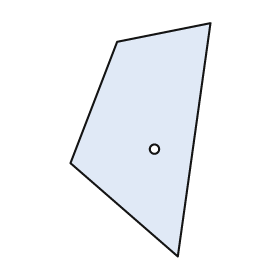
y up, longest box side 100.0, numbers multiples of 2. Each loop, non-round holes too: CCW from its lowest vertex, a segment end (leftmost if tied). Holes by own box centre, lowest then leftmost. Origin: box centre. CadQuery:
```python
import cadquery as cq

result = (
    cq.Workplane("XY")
    .moveTo(16.0, -50.0)
    .lineTo(30.0, 50.0)
    .lineTo(-10.0, 42.0)
    .lineTo(-30.0, -10.0)
    .close()
    .moveTo(6.0, -4.0)
    .circle(2.0)
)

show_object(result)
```